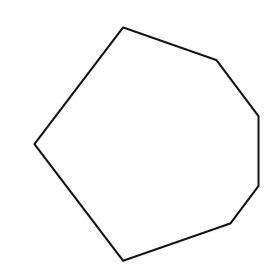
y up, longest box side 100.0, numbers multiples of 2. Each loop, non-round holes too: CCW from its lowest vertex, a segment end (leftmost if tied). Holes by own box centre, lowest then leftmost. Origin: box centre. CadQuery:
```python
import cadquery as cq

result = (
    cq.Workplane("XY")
    .moveTo(-10.0, -50.0)
    .lineTo(36.0, -34.0)
    .lineTo(48.0, -18.0)
    .lineTo(48.0, 12.0)
    .lineTo(30.0, 36.0)
    .lineTo(-10.0, 50.0)
    .lineTo(-48.0, 0.0)
    .close()
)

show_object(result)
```